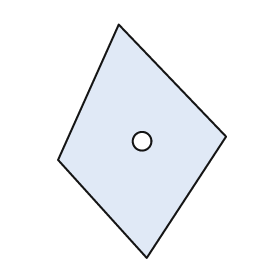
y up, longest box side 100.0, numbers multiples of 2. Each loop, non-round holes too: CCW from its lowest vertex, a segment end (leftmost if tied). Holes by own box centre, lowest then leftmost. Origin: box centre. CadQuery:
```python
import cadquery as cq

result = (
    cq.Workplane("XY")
    .moveTo(2.0, -50.0)
    .lineTo(36.0, 2.0)
    .lineTo(-10.0, 50.0)
    .lineTo(-36.0, -8.0)
    .close()
    .moveTo(0.0, 0.0)
    .circle(4.0)
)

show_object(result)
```